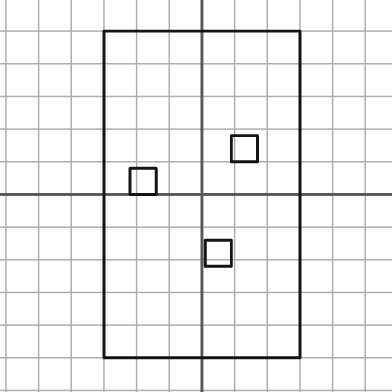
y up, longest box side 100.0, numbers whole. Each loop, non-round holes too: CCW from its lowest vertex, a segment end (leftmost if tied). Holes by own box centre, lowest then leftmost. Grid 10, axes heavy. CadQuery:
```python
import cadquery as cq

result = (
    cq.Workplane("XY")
    .moveTo(-30.0, -50.0)
    .lineTo(30.0, -50.0)
    .lineTo(30.0, 50.0)
    .lineTo(-30.0, 50.0)
    .close()
    .moveTo(1.0, -22.0)
    .lineTo(9.0, -22.0)
    .lineTo(9.0, -14.0)
    .lineTo(1.0, -14.0)
    .close()
    .moveTo(-22.0, 0.0)
    .lineTo(-14.0, 0.0)
    .lineTo(-14.0, 8.0)
    .lineTo(-22.0, 8.0)
    .close()
    .moveTo(9.0, 10.0)
    .lineTo(17.0, 10.0)
    .lineTo(17.0, 18.0)
    .lineTo(9.0, 18.0)
    .close()
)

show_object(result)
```